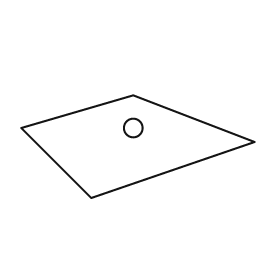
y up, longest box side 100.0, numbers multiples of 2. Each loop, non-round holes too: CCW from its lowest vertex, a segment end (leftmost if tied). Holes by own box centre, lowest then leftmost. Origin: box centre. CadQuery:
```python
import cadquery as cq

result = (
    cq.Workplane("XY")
    .moveTo(-20.0, -22.0)
    .lineTo(50.0, 2.0)
    .lineTo(-2.0, 22.0)
    .lineTo(-50.0, 8.0)
    .close()
    .moveTo(-2.0, 8.0)
    .circle(4.0)
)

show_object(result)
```